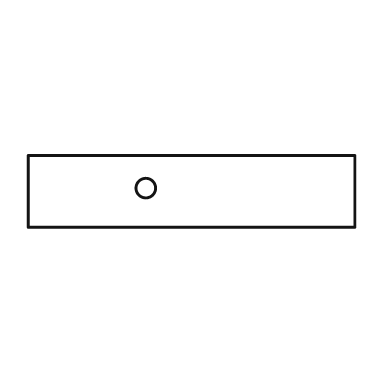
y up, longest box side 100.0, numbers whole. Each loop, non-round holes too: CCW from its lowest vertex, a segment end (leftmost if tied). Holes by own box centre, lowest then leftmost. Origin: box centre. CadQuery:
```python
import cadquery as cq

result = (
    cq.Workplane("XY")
    .moveTo(-50.0, -11.0)
    .lineTo(50.0, -11.0)
    .lineTo(50.0, 11.0)
    .lineTo(-50.0, 11.0)
    .close()
    .moveTo(-14.0, 1.0)
    .circle(3.0)
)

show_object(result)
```